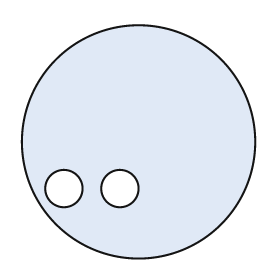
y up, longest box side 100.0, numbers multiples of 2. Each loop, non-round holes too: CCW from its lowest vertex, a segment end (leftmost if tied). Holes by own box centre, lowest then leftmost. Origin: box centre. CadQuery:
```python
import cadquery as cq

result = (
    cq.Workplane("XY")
    .moveTo(0.0, 0.0)
    .circle(50.0)
    .moveTo(-32.0, -20.0)
    .circle(8.0)
    .moveTo(-8.0, -20.0)
    .circle(8.0)
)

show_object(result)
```